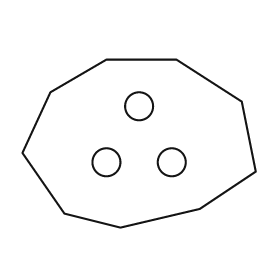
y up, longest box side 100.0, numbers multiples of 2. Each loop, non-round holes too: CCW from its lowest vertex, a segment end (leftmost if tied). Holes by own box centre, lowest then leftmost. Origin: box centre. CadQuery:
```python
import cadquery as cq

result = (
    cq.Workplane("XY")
    .moveTo(-8.0, -36.0)
    .lineTo(26.0, -28.0)
    .lineTo(50.0, -12.0)
    .lineTo(44.0, 18.0)
    .lineTo(16.0, 36.0)
    .lineTo(-14.0, 36.0)
    .lineTo(-38.0, 22.0)
    .lineTo(-50.0, -4.0)
    .lineTo(-32.0, -30.0)
    .close()
    .moveTo(-14.0, -8.0)
    .circle(6.0)
    .moveTo(14.0, -8.0)
    .circle(6.0)
    .moveTo(0.0, 16.0)
    .circle(6.0)
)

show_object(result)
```